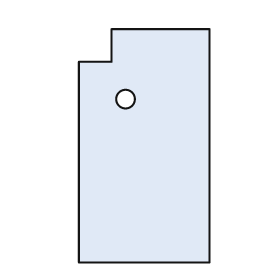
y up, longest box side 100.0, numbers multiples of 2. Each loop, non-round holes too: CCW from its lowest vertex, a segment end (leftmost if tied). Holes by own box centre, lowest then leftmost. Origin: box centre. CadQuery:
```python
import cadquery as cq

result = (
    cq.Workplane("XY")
    .moveTo(-28.0, -50.0)
    .lineTo(28.0, -50.0)
    .lineTo(28.0, 50.0)
    .lineTo(-14.0, 50.0)
    .lineTo(-14.0, 36.0)
    .lineTo(-28.0, 36.0)
    .close()
    .moveTo(-8.0, 20.0)
    .circle(4.0)
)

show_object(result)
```